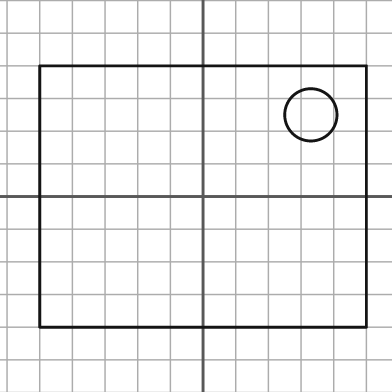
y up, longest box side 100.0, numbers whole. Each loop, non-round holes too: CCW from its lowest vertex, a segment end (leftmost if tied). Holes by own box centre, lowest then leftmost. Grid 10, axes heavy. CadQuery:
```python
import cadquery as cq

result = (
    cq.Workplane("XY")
    .moveTo(-50.0, -40.0)
    .lineTo(50.0, -40.0)
    .lineTo(50.0, 40.0)
    .lineTo(-50.0, 40.0)
    .close()
    .moveTo(33.0, 25.0)
    .circle(8.0)
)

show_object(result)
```